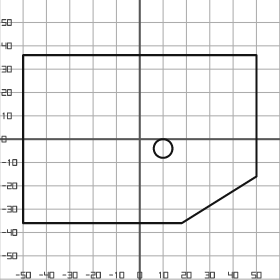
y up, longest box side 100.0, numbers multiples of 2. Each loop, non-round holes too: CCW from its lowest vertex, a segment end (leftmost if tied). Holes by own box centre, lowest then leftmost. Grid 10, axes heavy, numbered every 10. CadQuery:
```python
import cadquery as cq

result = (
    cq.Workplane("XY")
    .moveTo(-50.0, -36.0)
    .lineTo(18.0, -36.0)
    .lineTo(50.0, -16.0)
    .lineTo(50.0, 36.0)
    .lineTo(-50.0, 36.0)
    .close()
    .moveTo(10.0, -4.0)
    .circle(4.0)
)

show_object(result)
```